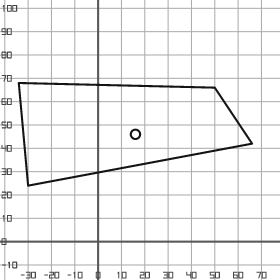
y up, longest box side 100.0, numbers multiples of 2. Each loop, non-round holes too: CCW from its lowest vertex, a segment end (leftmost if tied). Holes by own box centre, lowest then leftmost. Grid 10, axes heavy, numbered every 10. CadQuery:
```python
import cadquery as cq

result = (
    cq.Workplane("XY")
    .moveTo(-30.0, 24.0)
    .lineTo(66.0, 42.0)
    .lineTo(50.0, 66.0)
    .lineTo(-34.0, 68.0)
    .close()
    .moveTo(16.0, 46.0)
    .circle(2.0)
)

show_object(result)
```